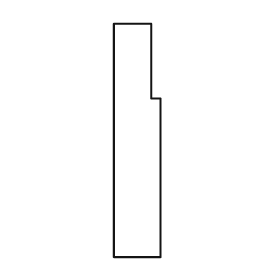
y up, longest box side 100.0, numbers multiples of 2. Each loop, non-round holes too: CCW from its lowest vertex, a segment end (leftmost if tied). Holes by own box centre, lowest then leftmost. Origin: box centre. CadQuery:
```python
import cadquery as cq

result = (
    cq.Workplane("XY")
    .moveTo(-10.0, -50.0)
    .lineTo(10.0, -50.0)
    .lineTo(10.0, 18.0)
    .lineTo(6.0, 18.0)
    .lineTo(6.0, 50.0)
    .lineTo(-10.0, 50.0)
    .close()
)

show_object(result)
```